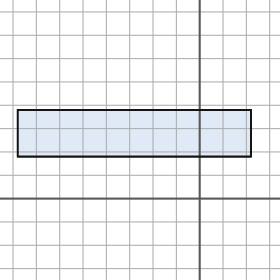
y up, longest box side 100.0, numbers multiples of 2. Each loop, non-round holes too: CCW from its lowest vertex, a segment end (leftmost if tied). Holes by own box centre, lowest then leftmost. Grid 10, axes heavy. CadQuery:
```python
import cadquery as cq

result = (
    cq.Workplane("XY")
    .moveTo(-78.0, 18.0)
    .lineTo(22.0, 18.0)
    .lineTo(22.0, 38.0)
    .lineTo(-78.0, 38.0)
    .close()
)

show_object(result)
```